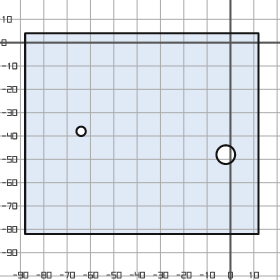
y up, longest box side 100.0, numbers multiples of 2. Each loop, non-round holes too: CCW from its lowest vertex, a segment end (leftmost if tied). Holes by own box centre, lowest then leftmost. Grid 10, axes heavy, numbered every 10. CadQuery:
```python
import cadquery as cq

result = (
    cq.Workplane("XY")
    .moveTo(-88.0, -82.0)
    .lineTo(12.0, -82.0)
    .lineTo(12.0, 4.0)
    .lineTo(-88.0, 4.0)
    .close()
    .moveTo(-2.0, -48.0)
    .circle(4.0)
    .moveTo(-64.0, -38.0)
    .circle(2.0)
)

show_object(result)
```